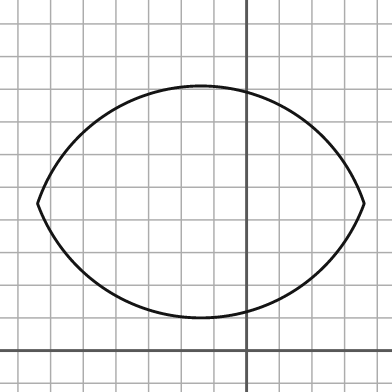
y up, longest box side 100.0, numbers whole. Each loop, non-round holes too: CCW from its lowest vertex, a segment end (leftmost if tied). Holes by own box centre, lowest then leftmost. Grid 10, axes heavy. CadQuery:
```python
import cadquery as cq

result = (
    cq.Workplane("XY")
    .moveTo(-64.0, 45.0)
    .threePointArc((-14.0, 10.0), (36.0, 45.0))
    .threePointArc((-14.0, 81.0), (-64.0, 45.0))
    .close()
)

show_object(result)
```